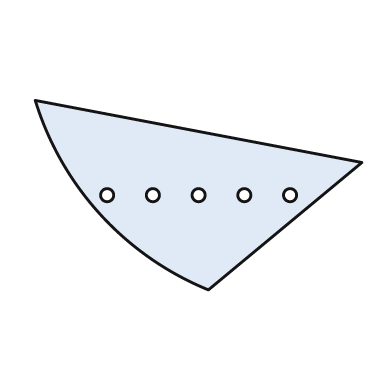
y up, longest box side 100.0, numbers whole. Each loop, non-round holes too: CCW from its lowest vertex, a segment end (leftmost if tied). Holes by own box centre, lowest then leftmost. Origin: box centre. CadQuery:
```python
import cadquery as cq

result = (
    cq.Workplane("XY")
    .moveTo(3.0, -29.0)
    .lineTo(50.0, 10.0)
    .lineTo(-50.0, 29.0)
    .threePointArc((-30.0, -6.0), (3.0, -29.0))
    .close()
    .moveTo(-28.0, 0.0)
    .circle(2.0)
    .moveTo(-14.0, 0.0)
    .circle(2.0)
    .moveTo(0.0, 0.0)
    .circle(2.0)
    .moveTo(14.0, 0.0)
    .circle(2.0)
    .moveTo(28.0, 0.0)
    .circle(2.0)
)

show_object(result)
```